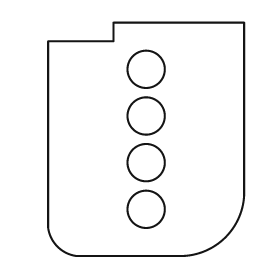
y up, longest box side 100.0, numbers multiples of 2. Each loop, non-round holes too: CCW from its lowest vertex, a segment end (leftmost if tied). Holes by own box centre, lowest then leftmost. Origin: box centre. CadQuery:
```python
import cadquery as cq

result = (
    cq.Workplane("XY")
    .moveTo(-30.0, -50.0)
    .lineTo(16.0, -50.0)
    .threePointArc((34.0, -42.0), (42.0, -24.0))
    .lineTo(42.0, 50.0)
    .lineTo(-14.0, 50.0)
    .lineTo(-14.0, 42.0)
    .lineTo(-42.0, 42.0)
    .lineTo(-42.0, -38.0)
    .threePointArc((-38.0, -46.0), (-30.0, -50.0))
    .close()
    .moveTo(0.0, -30.0)
    .circle(8.0)
    .moveTo(0.0, -10.0)
    .circle(8.0)
    .moveTo(0.0, 10.0)
    .circle(8.0)
    .moveTo(0.0, 30.0)
    .circle(8.0)
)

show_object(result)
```